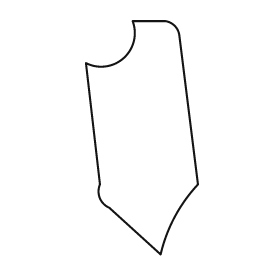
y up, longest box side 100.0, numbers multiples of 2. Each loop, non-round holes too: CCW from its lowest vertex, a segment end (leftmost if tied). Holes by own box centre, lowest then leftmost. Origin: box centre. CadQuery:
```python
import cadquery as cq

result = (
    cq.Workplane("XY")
    .moveTo(8.0, -50.0)
    .threePointArc((14.0, -34.0), (24.0, -20.0))
    .lineTo(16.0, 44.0)
    .threePointArc((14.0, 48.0), (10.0, 50.0))
    .lineTo(-4.0, 50.0)
    .threePointArc((-8.0, 34.0), (-24.0, 32.0))
    .lineTo(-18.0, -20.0)
    .threePointArc((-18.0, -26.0), (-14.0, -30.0))
    .close()
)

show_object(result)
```